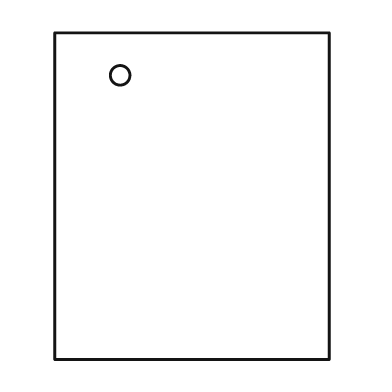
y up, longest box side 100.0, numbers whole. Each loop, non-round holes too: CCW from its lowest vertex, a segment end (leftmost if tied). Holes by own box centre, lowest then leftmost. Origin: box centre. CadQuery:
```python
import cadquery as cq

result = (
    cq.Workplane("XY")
    .moveTo(-42.0, -50.0)
    .lineTo(42.0, -50.0)
    .lineTo(42.0, 50.0)
    .lineTo(-42.0, 50.0)
    .close()
    .moveTo(-22.0, 37.0)
    .circle(3.0)
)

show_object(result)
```